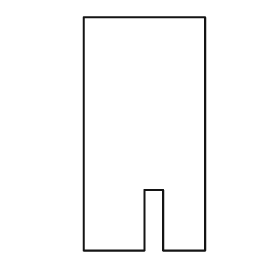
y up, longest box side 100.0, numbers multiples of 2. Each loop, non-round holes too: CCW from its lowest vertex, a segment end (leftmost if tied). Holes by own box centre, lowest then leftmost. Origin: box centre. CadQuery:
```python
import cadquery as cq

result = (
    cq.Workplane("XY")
    .moveTo(-26.0, -50.0)
    .lineTo(0.0, -50.0)
    .lineTo(0.0, -24.0)
    .lineTo(8.0, -24.0)
    .lineTo(8.0, -50.0)
    .lineTo(26.0, -50.0)
    .lineTo(26.0, 50.0)
    .lineTo(-26.0, 50.0)
    .close()
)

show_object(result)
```